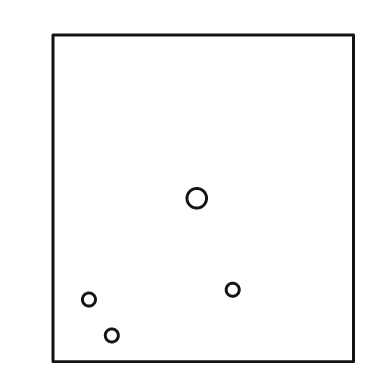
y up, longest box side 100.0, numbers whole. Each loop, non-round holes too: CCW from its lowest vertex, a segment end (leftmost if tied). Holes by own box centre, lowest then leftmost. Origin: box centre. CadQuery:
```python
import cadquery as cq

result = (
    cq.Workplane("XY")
    .moveTo(-46.0, -50.0)
    .lineTo(46.0, -50.0)
    .lineTo(46.0, 50.0)
    .lineTo(-46.0, 50.0)
    .close()
    .moveTo(-28.0, -42.0)
    .circle(2.0)
    .moveTo(-35.0, -31.0)
    .circle(2.0)
    .moveTo(9.0, -28.0)
    .circle(2.0)
    .moveTo(-2.0, 0.0)
    .circle(3.0)
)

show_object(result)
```